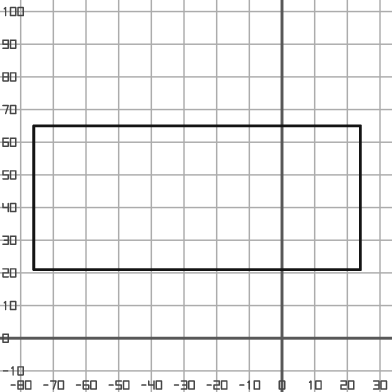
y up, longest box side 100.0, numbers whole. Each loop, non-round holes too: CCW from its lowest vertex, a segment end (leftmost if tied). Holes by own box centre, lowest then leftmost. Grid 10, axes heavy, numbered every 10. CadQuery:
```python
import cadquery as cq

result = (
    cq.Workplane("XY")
    .moveTo(-76.0, 21.0)
    .lineTo(24.0, 21.0)
    .lineTo(24.0, 65.0)
    .lineTo(-76.0, 65.0)
    .close()
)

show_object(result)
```